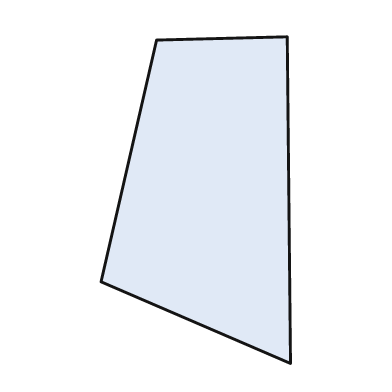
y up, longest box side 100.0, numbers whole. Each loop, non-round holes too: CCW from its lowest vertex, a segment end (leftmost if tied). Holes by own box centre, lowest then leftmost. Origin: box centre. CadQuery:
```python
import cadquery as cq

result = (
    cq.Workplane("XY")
    .moveTo(29.0, -50.0)
    .lineTo(28.0, 50.0)
    .lineTo(-12.0, 49.0)
    .lineTo(-29.0, -25.0)
    .close()
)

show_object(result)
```